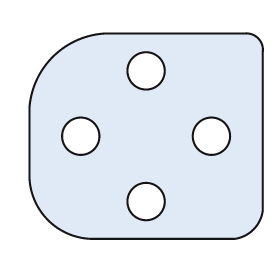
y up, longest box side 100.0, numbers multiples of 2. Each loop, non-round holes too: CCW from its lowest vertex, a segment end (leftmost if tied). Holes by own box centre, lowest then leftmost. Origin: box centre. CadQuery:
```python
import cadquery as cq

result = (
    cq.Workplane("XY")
    .moveTo(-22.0, -44.0)
    .lineTo(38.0, -44.0)
    .threePointArc((46.0, -40.0), (50.0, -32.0))
    .lineTo(50.0, 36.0)
    .threePointArc((48.0, 42.0), (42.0, 44.0))
    .lineTo(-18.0, 44.0)
    .threePointArc((-40.0, 34.0), (-50.0, 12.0))
    .lineTo(-50.0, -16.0)
    .threePointArc((-42.0, -36.0), (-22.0, -44.0))
    .close()
    .moveTo(0.0, -28.0)
    .circle(8.0)
    .moveTo(-28.0, 0.0)
    .circle(8.0)
    .moveTo(28.0, 0.0)
    .circle(8.0)
    .moveTo(0.0, 28.0)
    .circle(8.0)
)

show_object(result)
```